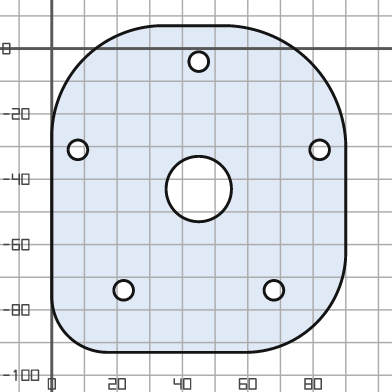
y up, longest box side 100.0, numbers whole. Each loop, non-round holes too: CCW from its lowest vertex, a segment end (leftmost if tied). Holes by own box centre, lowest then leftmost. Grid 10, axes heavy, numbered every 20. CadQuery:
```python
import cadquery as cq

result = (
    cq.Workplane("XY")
    .moveTo(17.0, -93.0)
    .lineTo(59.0, -93.0)
    .threePointArc((81.0, -84.0), (90.0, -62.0))
    .lineTo(90.0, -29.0)
    .threePointArc((79.0, -4.0), (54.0, 7.0))
    .lineTo(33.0, 7.0)
    .threePointArc((10.0, -3.0), (0.0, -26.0))
    .lineTo(0.0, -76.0)
    .threePointArc((5.0, -88.0), (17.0, -93.0))
    .close()
    .moveTo(22.0, -74.0)
    .circle(3.0)
    .moveTo(68.0, -74.0)
    .circle(3.0)
    .moveTo(45.0, -43.0)
    .circle(10.0)
    .moveTo(8.0, -31.0)
    .circle(3.0)
    .moveTo(82.0, -31.0)
    .circle(3.0)
    .moveTo(45.0, -4.0)
    .circle(3.0)
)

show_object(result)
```